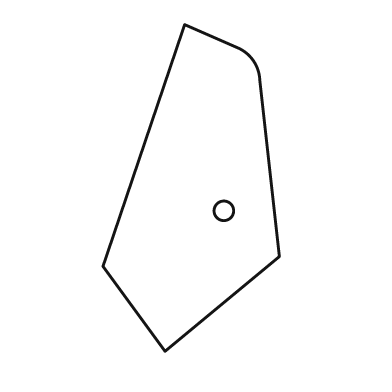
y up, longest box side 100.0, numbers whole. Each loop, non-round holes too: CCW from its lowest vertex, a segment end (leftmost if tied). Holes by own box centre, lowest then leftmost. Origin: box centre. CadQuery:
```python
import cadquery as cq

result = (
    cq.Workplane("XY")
    .moveTo(-8.0, -50.0)
    .lineTo(27.0, -21.0)
    .lineTo(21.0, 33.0)
    .threePointArc((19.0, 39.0), (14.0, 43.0))
    .lineTo(-2.0, 50.0)
    .lineTo(-27.0, -24.0)
    .close()
    .moveTo(10.0, -7.0)
    .circle(3.0)
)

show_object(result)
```